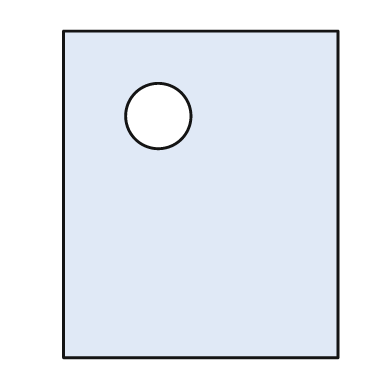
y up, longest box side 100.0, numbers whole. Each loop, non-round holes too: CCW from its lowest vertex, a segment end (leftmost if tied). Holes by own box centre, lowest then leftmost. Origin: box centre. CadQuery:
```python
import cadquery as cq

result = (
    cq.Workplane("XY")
    .moveTo(-42.0, -50.0)
    .lineTo(42.0, -50.0)
    .lineTo(42.0, 50.0)
    .lineTo(-42.0, 50.0)
    .close()
    .moveTo(-13.0, 24.0)
    .circle(10.0)
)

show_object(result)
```